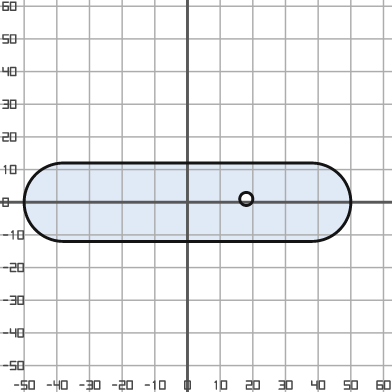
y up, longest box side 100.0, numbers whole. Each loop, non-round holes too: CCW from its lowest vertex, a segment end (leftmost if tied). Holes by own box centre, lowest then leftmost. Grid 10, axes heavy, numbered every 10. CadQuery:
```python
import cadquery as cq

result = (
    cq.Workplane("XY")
    .moveTo(-38.0, -12.0)
    .lineTo(38.0, -12.0)
    .threePointArc((50.0, 0.0), (38.0, 12.0))
    .lineTo(-38.0, 12.0)
    .threePointArc((-50.0, 0.0), (-38.0, -12.0))
    .close()
    .moveTo(18.0, 1.0)
    .circle(2.0)
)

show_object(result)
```